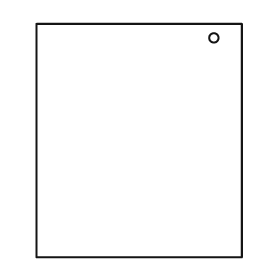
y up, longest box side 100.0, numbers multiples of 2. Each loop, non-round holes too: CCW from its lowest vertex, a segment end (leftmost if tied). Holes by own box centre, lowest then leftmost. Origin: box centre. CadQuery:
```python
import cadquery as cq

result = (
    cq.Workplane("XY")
    .moveTo(-44.0, -50.0)
    .lineTo(44.0, -50.0)
    .lineTo(44.0, 50.0)
    .lineTo(-44.0, 50.0)
    .close()
    .moveTo(32.0, 44.0)
    .circle(2.0)
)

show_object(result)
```